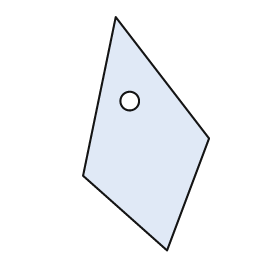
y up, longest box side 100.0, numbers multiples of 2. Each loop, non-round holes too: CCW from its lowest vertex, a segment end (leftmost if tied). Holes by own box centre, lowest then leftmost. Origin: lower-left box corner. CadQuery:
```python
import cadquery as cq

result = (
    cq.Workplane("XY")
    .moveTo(36.0, 0.0)
    .lineTo(54.0, 48.0)
    .lineTo(14.0, 100.0)
    .lineTo(0.0, 32.0)
    .close()
    .moveTo(20.0, 64.0)
    .circle(4.0)
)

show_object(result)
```